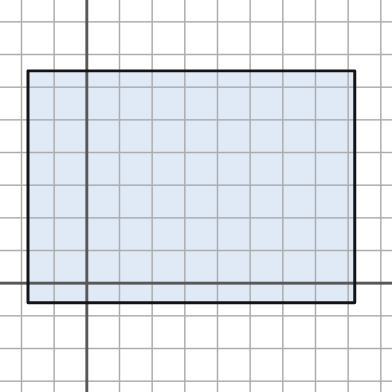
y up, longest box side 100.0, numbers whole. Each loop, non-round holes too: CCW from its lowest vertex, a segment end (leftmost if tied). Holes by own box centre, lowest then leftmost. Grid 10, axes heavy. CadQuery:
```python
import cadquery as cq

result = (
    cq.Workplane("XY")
    .moveTo(-18.0, -6.0)
    .lineTo(82.0, -6.0)
    .lineTo(82.0, 65.0)
    .lineTo(-18.0, 65.0)
    .close()
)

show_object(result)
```